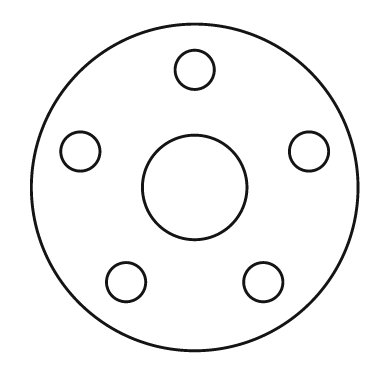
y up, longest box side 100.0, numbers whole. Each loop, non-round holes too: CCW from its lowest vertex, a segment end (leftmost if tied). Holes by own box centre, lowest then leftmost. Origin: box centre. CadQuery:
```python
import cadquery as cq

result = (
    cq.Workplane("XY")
    .moveTo(0.0, 0.0)
    .circle(50.0)
    .moveTo(-21.0, -29.0)
    .circle(6.0)
    .moveTo(21.0, -29.0)
    .circle(6.0)
    .moveTo(0.0, 0.0)
    .circle(16.0)
    .moveTo(-35.0, 11.0)
    .circle(6.0)
    .moveTo(35.0, 11.0)
    .circle(6.0)
    .moveTo(0.0, 36.0)
    .circle(6.0)
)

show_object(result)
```